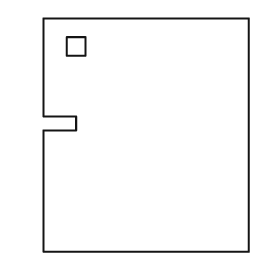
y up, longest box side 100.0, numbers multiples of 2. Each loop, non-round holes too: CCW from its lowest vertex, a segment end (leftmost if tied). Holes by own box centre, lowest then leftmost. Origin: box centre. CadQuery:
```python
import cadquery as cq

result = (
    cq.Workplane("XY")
    .moveTo(-44.0, -50.0)
    .lineTo(44.0, -50.0)
    .lineTo(44.0, 50.0)
    .lineTo(-44.0, 50.0)
    .lineTo(-44.0, 8.0)
    .lineTo(-30.0, 8.0)
    .lineTo(-30.0, 2.0)
    .lineTo(-44.0, 2.0)
    .close()
    .moveTo(-34.0, 34.0)
    .lineTo(-26.0, 34.0)
    .lineTo(-26.0, 42.0)
    .lineTo(-34.0, 42.0)
    .close()
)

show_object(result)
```